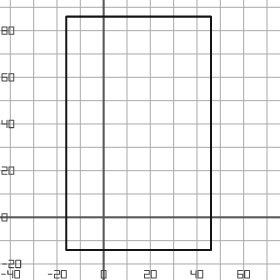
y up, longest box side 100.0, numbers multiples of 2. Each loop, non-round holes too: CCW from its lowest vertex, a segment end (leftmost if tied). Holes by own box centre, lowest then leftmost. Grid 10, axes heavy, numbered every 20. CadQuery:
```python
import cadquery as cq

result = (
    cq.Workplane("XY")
    .moveTo(-16.0, -14.0)
    .lineTo(46.0, -14.0)
    .lineTo(46.0, 86.0)
    .lineTo(-16.0, 86.0)
    .close()
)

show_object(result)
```